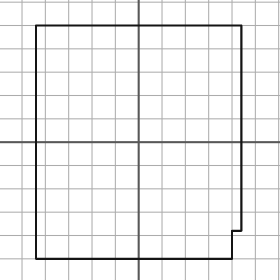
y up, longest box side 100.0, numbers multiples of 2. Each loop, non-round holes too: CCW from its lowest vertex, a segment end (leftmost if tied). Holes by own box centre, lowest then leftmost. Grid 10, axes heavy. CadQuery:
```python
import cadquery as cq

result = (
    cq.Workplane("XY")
    .moveTo(-44.0, -50.0)
    .lineTo(40.0, -50.0)
    .lineTo(40.0, -38.0)
    .lineTo(44.0, -38.0)
    .lineTo(44.0, 50.0)
    .lineTo(-44.0, 50.0)
    .close()
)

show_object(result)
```